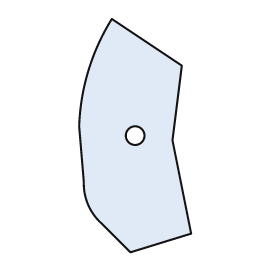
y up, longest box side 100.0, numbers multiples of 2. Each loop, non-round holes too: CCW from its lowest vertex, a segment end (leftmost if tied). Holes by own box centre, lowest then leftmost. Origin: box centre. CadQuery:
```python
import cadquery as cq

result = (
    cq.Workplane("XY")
    .moveTo(-2.0, -50.0)
    .lineTo(24.0, -42.0)
    .lineTo(16.0, -2.0)
    .lineTo(20.0, 30.0)
    .lineTo(-10.0, 50.0)
    .threePointArc((-20.0, 28.0), (-24.0, 4.0))
    .lineTo(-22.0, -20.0)
    .threePointArc((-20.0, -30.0), (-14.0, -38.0))
    .close()
    .moveTo(0.0, 0.0)
    .circle(4.0)
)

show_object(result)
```